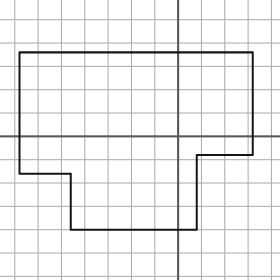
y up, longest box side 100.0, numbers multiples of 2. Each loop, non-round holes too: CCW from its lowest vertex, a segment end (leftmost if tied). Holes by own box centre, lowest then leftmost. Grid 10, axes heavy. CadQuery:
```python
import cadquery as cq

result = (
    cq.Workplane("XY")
    .moveTo(-46.0, -40.0)
    .lineTo(8.0, -40.0)
    .lineTo(8.0, -8.0)
    .lineTo(32.0, -8.0)
    .lineTo(32.0, 36.0)
    .lineTo(-68.0, 36.0)
    .lineTo(-68.0, -16.0)
    .lineTo(-46.0, -16.0)
    .close()
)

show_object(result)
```